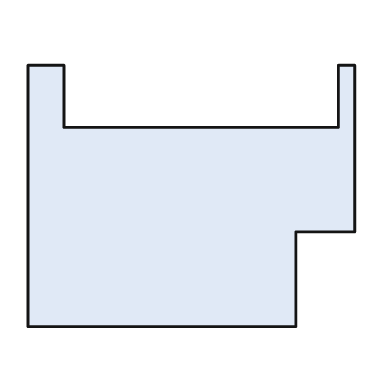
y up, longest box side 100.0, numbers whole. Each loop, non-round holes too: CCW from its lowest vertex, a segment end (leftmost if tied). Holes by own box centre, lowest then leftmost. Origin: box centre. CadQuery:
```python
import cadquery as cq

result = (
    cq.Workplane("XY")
    .moveTo(-50.0, -40.0)
    .lineTo(32.0, -40.0)
    .lineTo(32.0, -11.0)
    .lineTo(50.0, -11.0)
    .lineTo(50.0, 40.0)
    .lineTo(45.0, 40.0)
    .lineTo(45.0, 21.0)
    .lineTo(-39.0, 21.0)
    .lineTo(-39.0, 40.0)
    .lineTo(-50.0, 40.0)
    .close()
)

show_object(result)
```